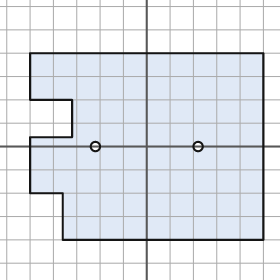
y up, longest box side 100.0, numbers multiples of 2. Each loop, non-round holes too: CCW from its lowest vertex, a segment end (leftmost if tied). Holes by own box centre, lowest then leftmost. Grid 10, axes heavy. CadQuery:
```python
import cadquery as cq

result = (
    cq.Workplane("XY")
    .moveTo(-36.0, -40.0)
    .lineTo(50.0, -40.0)
    .lineTo(50.0, 40.0)
    .lineTo(-50.0, 40.0)
    .lineTo(-50.0, 20.0)
    .lineTo(-32.0, 20.0)
    .lineTo(-32.0, 4.0)
    .lineTo(-50.0, 4.0)
    .lineTo(-50.0, -20.0)
    .lineTo(-36.0, -20.0)
    .close()
    .moveTo(-22.0, 0.0)
    .circle(2.0)
    .moveTo(22.0, 0.0)
    .circle(2.0)
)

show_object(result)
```